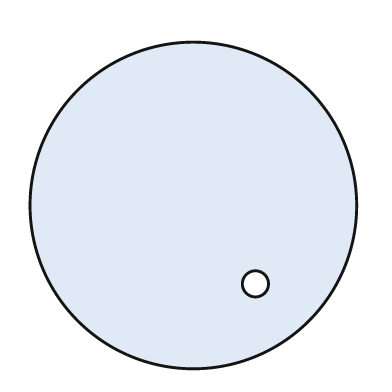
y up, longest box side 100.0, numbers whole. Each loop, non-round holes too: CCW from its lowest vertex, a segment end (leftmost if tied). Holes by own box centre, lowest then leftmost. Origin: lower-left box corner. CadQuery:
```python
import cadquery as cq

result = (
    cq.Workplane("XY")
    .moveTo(50.0, 50.0)
    .circle(50.0)
    .moveTo(69.0, 26.0)
    .circle(4.0)
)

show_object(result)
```